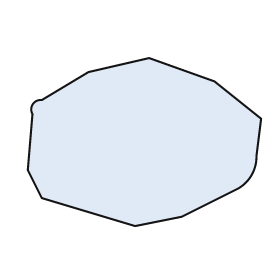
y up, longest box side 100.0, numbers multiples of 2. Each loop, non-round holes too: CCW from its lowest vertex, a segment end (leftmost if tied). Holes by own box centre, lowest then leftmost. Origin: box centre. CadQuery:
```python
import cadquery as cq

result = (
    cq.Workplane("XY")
    .moveTo(-4.0, -36.0)
    .lineTo(16.0, -32.0)
    .lineTo(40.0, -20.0)
    .threePointArc((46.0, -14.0), (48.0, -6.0))
    .lineTo(50.0, 10.0)
    .lineTo(30.0, 26.0)
    .lineTo(2.0, 36.0)
    .lineTo(-24.0, 30.0)
    .lineTo(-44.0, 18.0)
    .threePointArc((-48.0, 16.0), (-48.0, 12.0))
    .lineTo(-50.0, -12.0)
    .lineTo(-44.0, -24.0)
    .close()
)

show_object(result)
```